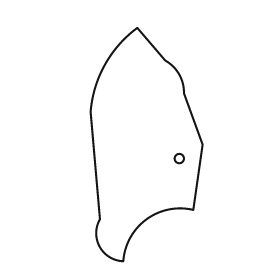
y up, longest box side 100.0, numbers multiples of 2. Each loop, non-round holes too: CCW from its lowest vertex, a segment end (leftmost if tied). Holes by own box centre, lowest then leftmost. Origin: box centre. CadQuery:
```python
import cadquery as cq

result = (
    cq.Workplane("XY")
    .moveTo(-10.0, -50.0)
    .threePointArc((0.0, -32.0), (20.0, -28.0))
    .lineTo(24.0, 0.0)
    .lineTo(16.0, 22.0)
    .threePointArc((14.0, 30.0), (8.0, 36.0))
    .lineTo(-4.0, 50.0)
    .threePointArc((-18.0, 34.0), (-24.0, 14.0))
    .lineTo(-20.0, -32.0)
    .threePointArc((-20.0, -44.0), (-10.0, -50.0))
    .close()
    .moveTo(14.0, -6.0)
    .circle(2.0)
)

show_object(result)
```